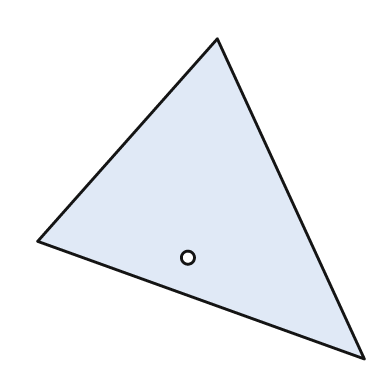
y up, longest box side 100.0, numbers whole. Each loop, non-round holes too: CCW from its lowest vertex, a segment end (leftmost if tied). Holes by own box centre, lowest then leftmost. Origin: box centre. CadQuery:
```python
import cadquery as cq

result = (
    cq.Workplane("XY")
    .moveTo(50.0, -49.0)
    .lineTo(5.0, 49.0)
    .lineTo(-50.0, -13.0)
    .close()
    .moveTo(-4.0, -18.0)
    .circle(2.0)
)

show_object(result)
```